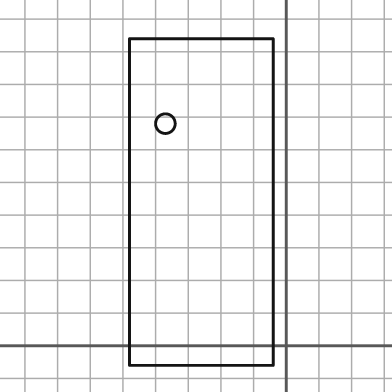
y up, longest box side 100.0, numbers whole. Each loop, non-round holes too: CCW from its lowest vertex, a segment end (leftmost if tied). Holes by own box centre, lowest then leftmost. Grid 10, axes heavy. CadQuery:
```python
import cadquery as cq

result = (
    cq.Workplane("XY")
    .moveTo(-48.0, -6.0)
    .lineTo(-4.0, -6.0)
    .lineTo(-4.0, 94.0)
    .lineTo(-48.0, 94.0)
    .close()
    .moveTo(-37.0, 68.0)
    .circle(3.0)
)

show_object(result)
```